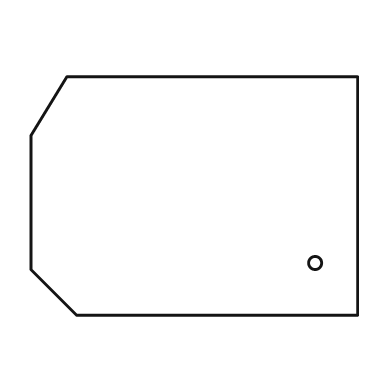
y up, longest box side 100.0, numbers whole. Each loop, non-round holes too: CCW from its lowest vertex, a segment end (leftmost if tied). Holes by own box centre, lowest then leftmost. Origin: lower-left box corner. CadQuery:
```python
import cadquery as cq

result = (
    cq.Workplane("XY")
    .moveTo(14.0, 0.0)
    .lineTo(100.0, 0.0)
    .lineTo(100.0, 73.0)
    .lineTo(11.0, 73.0)
    .lineTo(0.0, 55.0)
    .lineTo(0.0, 14.0)
    .close()
    .moveTo(87.0, 16.0)
    .circle(2.0)
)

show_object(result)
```